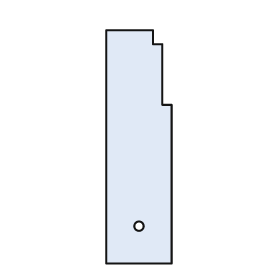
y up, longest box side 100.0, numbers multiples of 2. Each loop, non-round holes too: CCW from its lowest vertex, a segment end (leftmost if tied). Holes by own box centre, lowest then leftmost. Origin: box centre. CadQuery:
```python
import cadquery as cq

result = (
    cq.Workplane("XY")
    .moveTo(-14.0, -50.0)
    .lineTo(14.0, -50.0)
    .lineTo(14.0, 18.0)
    .lineTo(10.0, 18.0)
    .lineTo(10.0, 44.0)
    .lineTo(6.0, 44.0)
    .lineTo(6.0, 50.0)
    .lineTo(-14.0, 50.0)
    .close()
    .moveTo(0.0, -34.0)
    .circle(2.0)
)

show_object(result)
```